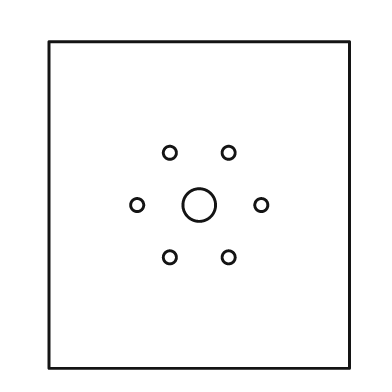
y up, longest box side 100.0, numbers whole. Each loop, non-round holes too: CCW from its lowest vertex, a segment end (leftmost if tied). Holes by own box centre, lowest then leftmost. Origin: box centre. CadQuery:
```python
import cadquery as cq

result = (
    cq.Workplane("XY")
    .moveTo(-46.0, -50.0)
    .lineTo(46.0, -50.0)
    .lineTo(46.0, 50.0)
    .lineTo(-46.0, 50.0)
    .close()
    .moveTo(-9.0, -16.0)
    .circle(2.0)
    .moveTo(9.0, -16.0)
    .circle(2.0)
    .moveTo(-19.0, 0.0)
    .circle(2.0)
    .moveTo(0.0, 0.0)
    .circle(5.0)
    .moveTo(19.0, 0.0)
    .circle(2.0)
    .moveTo(-9.0, 16.0)
    .circle(2.0)
    .moveTo(9.0, 16.0)
    .circle(2.0)
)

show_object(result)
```